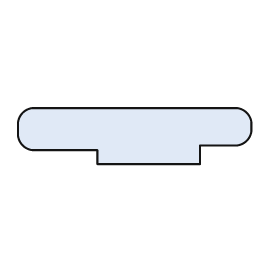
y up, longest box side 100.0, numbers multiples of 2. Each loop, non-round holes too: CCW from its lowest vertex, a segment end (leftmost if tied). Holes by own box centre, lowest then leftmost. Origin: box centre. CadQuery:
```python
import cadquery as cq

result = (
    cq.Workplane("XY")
    .moveTo(-16.0, -12.0)
    .lineTo(28.0, -12.0)
    .lineTo(28.0, -4.0)
    .lineTo(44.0, -4.0)
    .threePointArc((48.0, -2.0), (50.0, 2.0))
    .lineTo(50.0, 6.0)
    .threePointArc((48.0, 10.0), (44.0, 12.0))
    .lineTo(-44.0, 12.0)
    .threePointArc((-48.0, 10.0), (-50.0, 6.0))
    .lineTo(-50.0, 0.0)
    .threePointArc((-48.0, -4.0), (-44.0, -6.0))
    .lineTo(-16.0, -6.0)
    .close()
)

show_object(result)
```